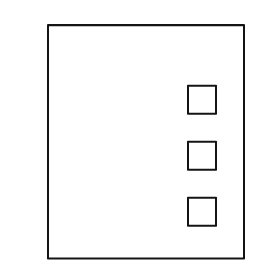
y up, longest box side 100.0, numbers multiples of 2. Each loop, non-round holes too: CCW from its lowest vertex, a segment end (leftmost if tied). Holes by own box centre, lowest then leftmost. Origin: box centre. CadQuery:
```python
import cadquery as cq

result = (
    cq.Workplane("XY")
    .moveTo(-42.0, -50.0)
    .lineTo(42.0, -50.0)
    .lineTo(42.0, 50.0)
    .lineTo(-42.0, 50.0)
    .close()
    .moveTo(18.0, -36.0)
    .lineTo(30.0, -36.0)
    .lineTo(30.0, -24.0)
    .lineTo(18.0, -24.0)
    .close()
    .moveTo(18.0, -12.0)
    .lineTo(30.0, -12.0)
    .lineTo(30.0, 0.0)
    .lineTo(18.0, 0.0)
    .close()
    .moveTo(18.0, 12.0)
    .lineTo(30.0, 12.0)
    .lineTo(30.0, 24.0)
    .lineTo(18.0, 24.0)
    .close()
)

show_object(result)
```